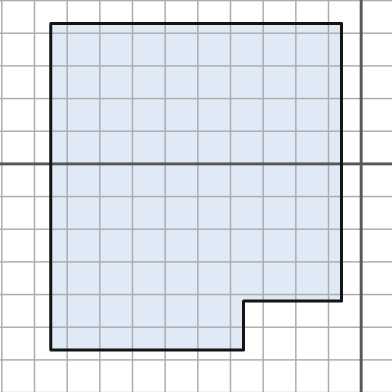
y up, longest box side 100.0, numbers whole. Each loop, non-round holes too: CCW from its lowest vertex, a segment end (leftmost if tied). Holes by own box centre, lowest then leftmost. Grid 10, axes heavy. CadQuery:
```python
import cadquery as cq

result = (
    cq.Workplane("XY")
    .moveTo(-95.0, -57.0)
    .lineTo(-36.0, -57.0)
    .lineTo(-36.0, -42.0)
    .lineTo(-6.0, -42.0)
    .lineTo(-6.0, 43.0)
    .lineTo(-95.0, 43.0)
    .close()
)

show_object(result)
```